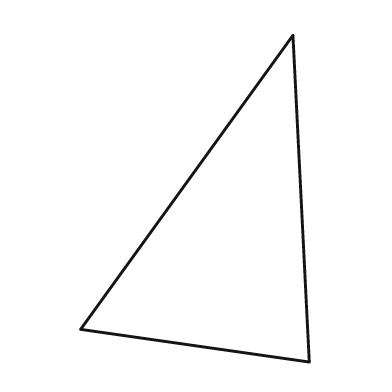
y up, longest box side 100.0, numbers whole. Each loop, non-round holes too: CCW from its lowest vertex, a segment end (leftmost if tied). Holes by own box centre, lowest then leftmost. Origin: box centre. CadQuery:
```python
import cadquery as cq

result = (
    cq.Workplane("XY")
    .moveTo(35.0, -50.0)
    .lineTo(30.0, 50.0)
    .lineTo(-35.0, -40.0)
    .close()
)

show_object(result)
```